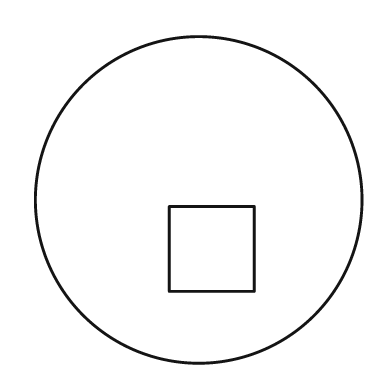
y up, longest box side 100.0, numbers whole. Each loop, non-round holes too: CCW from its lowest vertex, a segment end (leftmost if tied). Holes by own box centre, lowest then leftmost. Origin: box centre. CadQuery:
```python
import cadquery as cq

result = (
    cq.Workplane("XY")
    .moveTo(0.0, 0.0)
    .circle(50.0)
    .moveTo(-9.0, -28.0)
    .lineTo(17.0, -28.0)
    .lineTo(17.0, -2.0)
    .lineTo(-9.0, -2.0)
    .close()
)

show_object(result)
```